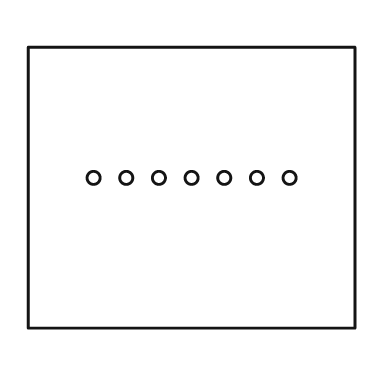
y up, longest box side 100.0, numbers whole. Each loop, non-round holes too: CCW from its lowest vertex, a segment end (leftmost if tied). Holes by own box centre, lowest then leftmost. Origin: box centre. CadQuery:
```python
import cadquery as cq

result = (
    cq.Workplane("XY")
    .moveTo(-50.0, -43.0)
    .lineTo(50.0, -43.0)
    .lineTo(50.0, 43.0)
    .lineTo(-50.0, 43.0)
    .close()
    .moveTo(-30.0, 3.0)
    .circle(2.0)
    .moveTo(-20.0, 3.0)
    .circle(2.0)
    .moveTo(-10.0, 3.0)
    .circle(2.0)
    .moveTo(0.0, 3.0)
    .circle(2.0)
    .moveTo(10.0, 3.0)
    .circle(2.0)
    .moveTo(20.0, 3.0)
    .circle(2.0)
    .moveTo(30.0, 3.0)
    .circle(2.0)
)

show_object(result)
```